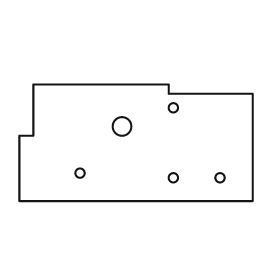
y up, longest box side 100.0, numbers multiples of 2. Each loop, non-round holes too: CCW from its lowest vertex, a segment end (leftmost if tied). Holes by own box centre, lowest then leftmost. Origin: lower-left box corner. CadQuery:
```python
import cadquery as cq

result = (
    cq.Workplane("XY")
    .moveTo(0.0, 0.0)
    .lineTo(100.0, 0.0)
    .lineTo(100.0, 46.0)
    .lineTo(64.0, 46.0)
    .lineTo(64.0, 50.0)
    .lineTo(6.0, 50.0)
    .lineTo(6.0, 28.0)
    .lineTo(0.0, 28.0)
    .close()
    .moveTo(66.0, 10.0)
    .circle(2.0)
    .moveTo(86.0, 10.0)
    .circle(2.0)
    .moveTo(26.0, 12.0)
    .circle(2.0)
    .moveTo(44.0, 32.0)
    .circle(4.0)
    .moveTo(66.0, 40.0)
    .circle(2.0)
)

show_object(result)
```